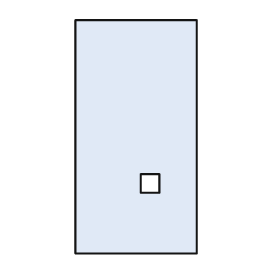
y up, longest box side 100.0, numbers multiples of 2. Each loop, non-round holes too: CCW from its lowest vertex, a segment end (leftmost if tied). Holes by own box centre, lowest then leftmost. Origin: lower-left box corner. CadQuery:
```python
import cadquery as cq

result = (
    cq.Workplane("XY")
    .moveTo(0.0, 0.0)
    .lineTo(52.0, 0.0)
    .lineTo(52.0, 100.0)
    .lineTo(0.0, 100.0)
    .close()
    .moveTo(28.0, 26.0)
    .lineTo(36.0, 26.0)
    .lineTo(36.0, 34.0)
    .lineTo(28.0, 34.0)
    .close()
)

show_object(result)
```